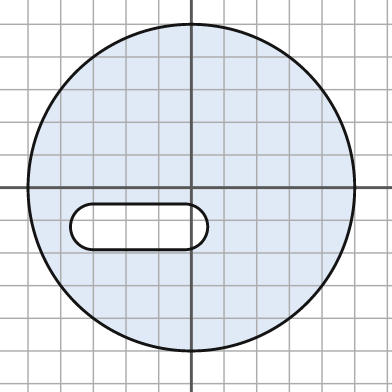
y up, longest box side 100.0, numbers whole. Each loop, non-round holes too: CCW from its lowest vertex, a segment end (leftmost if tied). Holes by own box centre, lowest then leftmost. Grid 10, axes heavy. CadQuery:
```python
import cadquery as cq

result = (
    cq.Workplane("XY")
    .moveTo(0.0, 0.0)
    .circle(50.0)
    .moveTo(-30.0, -19.0)
    .lineTo(-2.0, -19.0)
    .threePointArc((5.0, -12.0), (-2.0, -5.0))
    .lineTo(-30.0, -5.0)
    .threePointArc((-37.0, -12.0), (-30.0, -19.0))
    .close()
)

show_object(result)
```